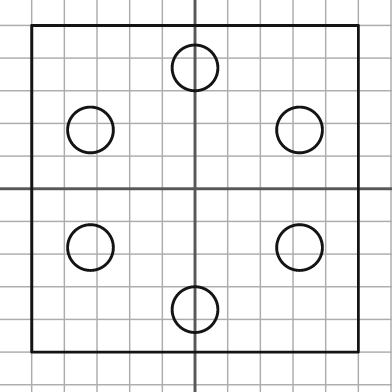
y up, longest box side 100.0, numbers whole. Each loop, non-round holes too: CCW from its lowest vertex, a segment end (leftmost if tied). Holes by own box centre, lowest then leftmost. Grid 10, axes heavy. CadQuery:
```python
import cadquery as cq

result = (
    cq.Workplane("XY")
    .moveTo(-50.0, -50.0)
    .lineTo(50.0, -50.0)
    .lineTo(50.0, 50.0)
    .lineTo(-50.0, 50.0)
    .close()
    .moveTo(0.0, -37.0)
    .circle(7.0)
    .moveTo(-32.0, -18.0)
    .circle(7.0)
    .moveTo(32.0, -18.0)
    .circle(7.0)
    .moveTo(-32.0, 18.0)
    .circle(7.0)
    .moveTo(32.0, 18.0)
    .circle(7.0)
    .moveTo(0.0, 37.0)
    .circle(7.0)
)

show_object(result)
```